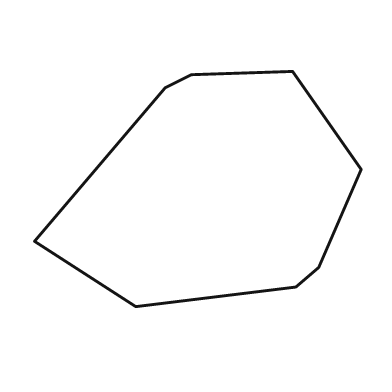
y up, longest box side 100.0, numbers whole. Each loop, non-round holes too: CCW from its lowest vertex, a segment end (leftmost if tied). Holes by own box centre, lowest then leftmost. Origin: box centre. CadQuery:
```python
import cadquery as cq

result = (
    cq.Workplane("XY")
    .moveTo(-19.0, -36.0)
    .lineTo(30.0, -30.0)
    .lineTo(37.0, -24.0)
    .lineTo(50.0, 6.0)
    .lineTo(29.0, 36.0)
    .lineTo(-2.0, 35.0)
    .lineTo(-10.0, 31.0)
    .lineTo(-50.0, -16.0)
    .close()
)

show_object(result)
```